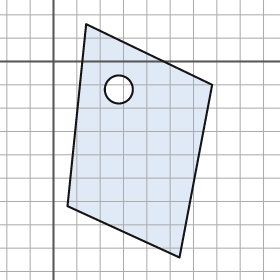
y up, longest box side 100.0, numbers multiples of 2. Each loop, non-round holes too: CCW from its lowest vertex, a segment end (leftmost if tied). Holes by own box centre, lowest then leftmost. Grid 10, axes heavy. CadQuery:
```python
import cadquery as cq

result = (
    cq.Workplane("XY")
    .moveTo(54.0, -84.0)
    .lineTo(68.0, -10.0)
    .lineTo(14.0, 16.0)
    .lineTo(6.0, -62.0)
    .close()
    .moveTo(28.0, -12.0)
    .circle(6.0)
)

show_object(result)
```